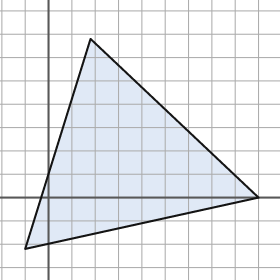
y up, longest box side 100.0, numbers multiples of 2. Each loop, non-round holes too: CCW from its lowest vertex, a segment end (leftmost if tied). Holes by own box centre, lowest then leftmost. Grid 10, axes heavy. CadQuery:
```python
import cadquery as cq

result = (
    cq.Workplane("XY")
    .moveTo(-10.0, -22.0)
    .lineTo(90.0, 0.0)
    .lineTo(18.0, 68.0)
    .close()
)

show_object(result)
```